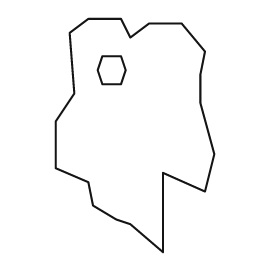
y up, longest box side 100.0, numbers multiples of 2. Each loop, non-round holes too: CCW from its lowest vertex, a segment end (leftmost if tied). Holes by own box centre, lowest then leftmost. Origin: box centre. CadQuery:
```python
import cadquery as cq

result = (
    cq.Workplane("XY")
    .moveTo(12.0, -50.0)
    .lineTo(12.0, -16.0)
    .lineTo(30.0, -24.0)
    .lineTo(34.0, -8.0)
    .lineTo(28.0, 14.0)
    .lineTo(28.0, 26.0)
    .lineTo(30.0, 36.0)
    .lineTo(20.0, 48.0)
    .lineTo(6.0, 48.0)
    .lineTo(-2.0, 42.0)
    .lineTo(-6.0, 50.0)
    .lineTo(-20.0, 50.0)
    .lineTo(-28.0, 44.0)
    .lineTo(-26.0, 18.0)
    .lineTo(-34.0, 6.0)
    .lineTo(-34.0, -14.0)
    .lineTo(-20.0, -20.0)
    .lineTo(-18.0, -30.0)
    .lineTo(-8.0, -36.0)
    .lineTo(-2.0, -38.0)
    .close()
    .moveTo(-14.0, 22.0)
    .lineTo(-6.0, 22.0)
    .lineTo(-4.0, 28.0)
    .lineTo(-6.0, 34.0)
    .lineTo(-14.0, 34.0)
    .lineTo(-16.0, 28.0)
    .close()
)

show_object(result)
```